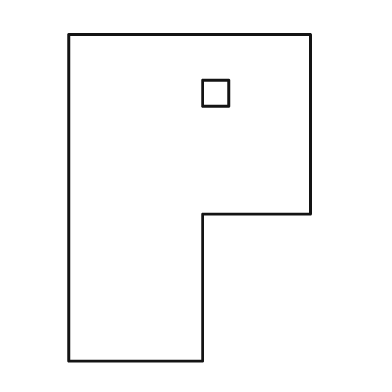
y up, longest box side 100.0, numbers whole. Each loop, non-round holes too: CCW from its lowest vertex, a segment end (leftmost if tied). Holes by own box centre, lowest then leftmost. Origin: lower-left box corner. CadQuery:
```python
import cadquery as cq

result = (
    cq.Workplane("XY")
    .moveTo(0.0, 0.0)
    .lineTo(41.0, 0.0)
    .lineTo(41.0, 45.0)
    .lineTo(74.0, 45.0)
    .lineTo(74.0, 100.0)
    .lineTo(0.0, 100.0)
    .close()
    .moveTo(41.0, 78.0)
    .lineTo(49.0, 78.0)
    .lineTo(49.0, 86.0)
    .lineTo(41.0, 86.0)
    .close()
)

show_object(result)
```